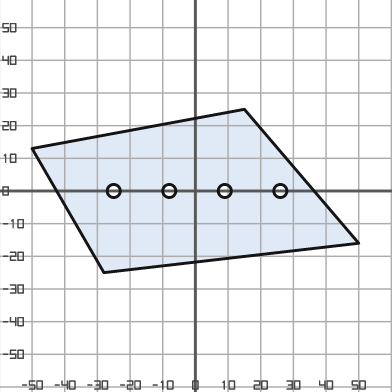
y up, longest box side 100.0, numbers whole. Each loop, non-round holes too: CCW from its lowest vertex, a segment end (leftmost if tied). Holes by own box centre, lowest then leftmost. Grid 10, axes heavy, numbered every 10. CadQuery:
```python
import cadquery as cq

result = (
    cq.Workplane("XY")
    .moveTo(-28.0, -25.0)
    .lineTo(50.0, -16.0)
    .lineTo(15.0, 25.0)
    .lineTo(-50.0, 13.0)
    .close()
    .moveTo(-25.0, 0.0)
    .circle(2.0)
    .moveTo(-8.0, 0.0)
    .circle(2.0)
    .moveTo(9.0, 0.0)
    .circle(2.0)
    .moveTo(26.0, 0.0)
    .circle(2.0)
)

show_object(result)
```